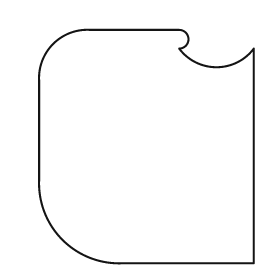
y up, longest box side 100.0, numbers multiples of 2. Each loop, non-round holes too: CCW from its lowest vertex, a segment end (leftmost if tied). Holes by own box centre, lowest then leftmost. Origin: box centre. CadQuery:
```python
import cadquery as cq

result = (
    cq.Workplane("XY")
    .moveTo(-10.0, -50.0)
    .lineTo(46.0, -50.0)
    .lineTo(46.0, 42.0)
    .threePointArc((30.0, 34.0), (14.0, 42.0))
    .threePointArc((18.0, 46.0), (14.0, 50.0))
    .lineTo(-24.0, 50.0)
    .threePointArc((-40.0, 44.0), (-46.0, 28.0))
    .lineTo(-46.0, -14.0)
    .threePointArc((-36.0, -40.0), (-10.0, -50.0))
    .close()
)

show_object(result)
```